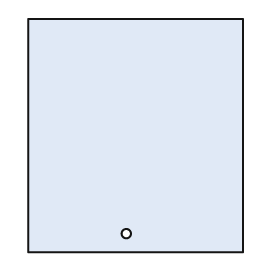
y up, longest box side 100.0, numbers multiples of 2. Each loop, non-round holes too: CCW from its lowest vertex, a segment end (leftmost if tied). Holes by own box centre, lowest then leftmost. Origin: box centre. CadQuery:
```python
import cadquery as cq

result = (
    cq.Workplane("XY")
    .moveTo(-46.0, -50.0)
    .lineTo(46.0, -50.0)
    .lineTo(46.0, 50.0)
    .lineTo(-46.0, 50.0)
    .close()
    .moveTo(-4.0, -42.0)
    .circle(2.0)
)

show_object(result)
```